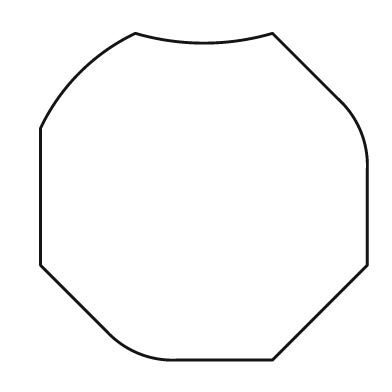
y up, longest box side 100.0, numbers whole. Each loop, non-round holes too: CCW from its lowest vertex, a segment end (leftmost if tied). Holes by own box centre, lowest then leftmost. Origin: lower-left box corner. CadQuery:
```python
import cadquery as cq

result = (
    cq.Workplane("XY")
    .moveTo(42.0, 0.0)
    .lineTo(71.0, 0.0)
    .lineTo(100.0, 29.0)
    .lineTo(100.0, 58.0)
    .threePointArc((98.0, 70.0), (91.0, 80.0))
    .lineTo(71.0, 100.0)
    .threePointArc((50.0, 97.0), (29.0, 100.0))
    .threePointArc((12.0, 88.0), (0.0, 71.0))
    .lineTo(0.0, 29.0)
    .lineTo(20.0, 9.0)
    .threePointArc((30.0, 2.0), (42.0, 0.0))
    .close()
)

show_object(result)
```